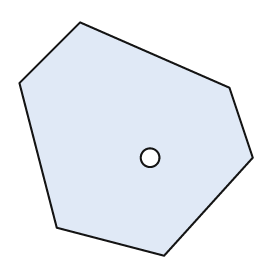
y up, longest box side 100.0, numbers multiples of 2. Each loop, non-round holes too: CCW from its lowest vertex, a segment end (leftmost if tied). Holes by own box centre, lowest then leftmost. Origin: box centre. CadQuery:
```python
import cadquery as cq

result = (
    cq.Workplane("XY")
    .moveTo(12.0, -50.0)
    .lineTo(50.0, -8.0)
    .lineTo(40.0, 22.0)
    .lineTo(-24.0, 50.0)
    .lineTo(-50.0, 24.0)
    .lineTo(-34.0, -38.0)
    .close()
    .moveTo(6.0, -8.0)
    .circle(4.0)
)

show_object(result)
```